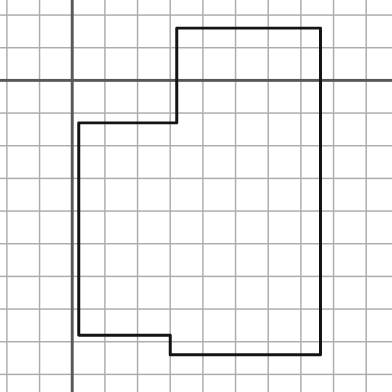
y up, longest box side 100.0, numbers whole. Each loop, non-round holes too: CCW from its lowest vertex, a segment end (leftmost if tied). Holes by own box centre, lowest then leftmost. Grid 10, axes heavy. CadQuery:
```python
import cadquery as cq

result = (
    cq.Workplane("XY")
    .moveTo(30.0, -84.0)
    .lineTo(76.0, -84.0)
    .lineTo(76.0, 16.0)
    .lineTo(32.0, 16.0)
    .lineTo(32.0, -13.0)
    .lineTo(2.0, -13.0)
    .lineTo(2.0, -78.0)
    .lineTo(30.0, -78.0)
    .close()
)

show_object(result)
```